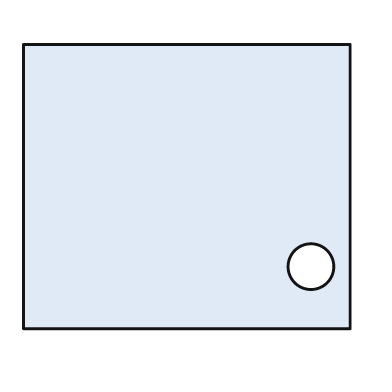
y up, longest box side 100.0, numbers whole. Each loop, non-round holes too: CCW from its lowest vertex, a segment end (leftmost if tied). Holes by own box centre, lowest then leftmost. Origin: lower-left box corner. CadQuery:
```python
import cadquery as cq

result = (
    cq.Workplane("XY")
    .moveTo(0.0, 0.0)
    .lineTo(100.0, 0.0)
    .lineTo(100.0, 87.0)
    .lineTo(0.0, 87.0)
    .close()
    .moveTo(88.0, 19.0)
    .circle(7.0)
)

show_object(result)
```